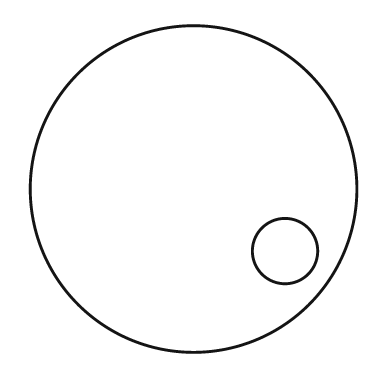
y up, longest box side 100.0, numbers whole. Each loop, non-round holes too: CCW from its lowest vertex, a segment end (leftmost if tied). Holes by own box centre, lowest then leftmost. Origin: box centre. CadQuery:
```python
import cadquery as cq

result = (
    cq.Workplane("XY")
    .moveTo(0.0, 0.0)
    .circle(50.0)
    .moveTo(28.0, -19.0)
    .circle(10.0)
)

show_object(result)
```